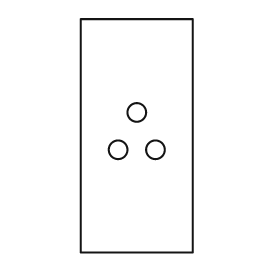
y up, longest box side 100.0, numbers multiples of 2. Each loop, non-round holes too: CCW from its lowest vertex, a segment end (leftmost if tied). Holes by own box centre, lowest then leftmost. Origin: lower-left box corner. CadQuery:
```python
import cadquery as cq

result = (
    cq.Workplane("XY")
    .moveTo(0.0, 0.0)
    .lineTo(48.0, 0.0)
    .lineTo(48.0, 100.0)
    .lineTo(0.0, 100.0)
    .close()
    .moveTo(16.0, 44.0)
    .circle(4.0)
    .moveTo(32.0, 44.0)
    .circle(4.0)
    .moveTo(24.0, 60.0)
    .circle(4.0)
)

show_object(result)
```